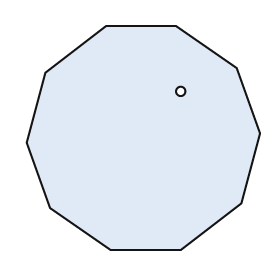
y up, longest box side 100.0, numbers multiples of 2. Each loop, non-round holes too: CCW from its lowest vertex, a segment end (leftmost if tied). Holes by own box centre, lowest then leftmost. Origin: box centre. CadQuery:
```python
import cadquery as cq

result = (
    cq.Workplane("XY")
    .moveTo(-14.0, -48.0)
    .lineTo(16.0, -48.0)
    .lineTo(42.0, -28.0)
    .lineTo(50.0, 2.0)
    .lineTo(40.0, 30.0)
    .lineTo(14.0, 48.0)
    .lineTo(-16.0, 48.0)
    .lineTo(-42.0, 28.0)
    .lineTo(-50.0, -2.0)
    .lineTo(-40.0, -30.0)
    .close()
    .moveTo(16.0, 20.0)
    .circle(2.0)
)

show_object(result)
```